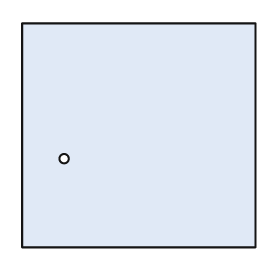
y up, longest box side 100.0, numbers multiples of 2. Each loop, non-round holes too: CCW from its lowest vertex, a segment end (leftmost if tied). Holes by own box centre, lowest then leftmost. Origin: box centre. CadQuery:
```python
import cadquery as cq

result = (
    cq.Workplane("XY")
    .moveTo(-50.0, -48.0)
    .lineTo(50.0, -48.0)
    .lineTo(50.0, 48.0)
    .lineTo(-50.0, 48.0)
    .close()
    .moveTo(-32.0, -10.0)
    .circle(2.0)
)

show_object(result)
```